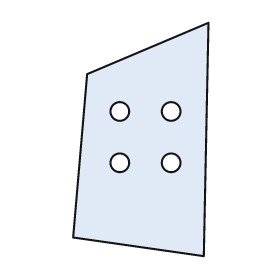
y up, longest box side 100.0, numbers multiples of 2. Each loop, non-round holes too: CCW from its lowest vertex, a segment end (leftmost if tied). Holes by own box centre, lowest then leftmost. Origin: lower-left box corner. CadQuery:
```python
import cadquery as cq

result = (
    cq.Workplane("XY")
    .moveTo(56.0, 0.0)
    .lineTo(58.0, 100.0)
    .lineTo(6.0, 78.0)
    .lineTo(0.0, 8.0)
    .close()
    .moveTo(20.0, 40.0)
    .circle(4.0)
    .moveTo(42.0, 40.0)
    .circle(4.0)
    .moveTo(20.0, 62.0)
    .circle(4.0)
    .moveTo(42.0, 62.0)
    .circle(4.0)
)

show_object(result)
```